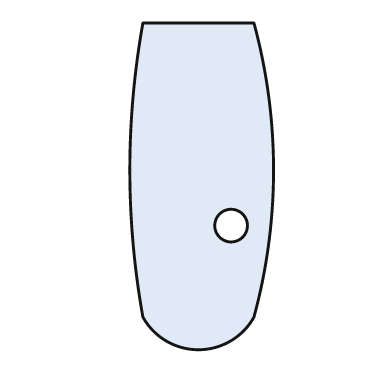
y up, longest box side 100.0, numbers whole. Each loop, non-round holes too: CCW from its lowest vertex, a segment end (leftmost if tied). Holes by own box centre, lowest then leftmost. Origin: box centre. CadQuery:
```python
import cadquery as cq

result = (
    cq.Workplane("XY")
    .moveTo(-18.0, -40.0)
    .threePointArc((-1.0, -50.0), (16.0, -40.0))
    .threePointArc((22.0, 5.0), (16.0, 50.0))
    .lineTo(-18.0, 50.0)
    .threePointArc((-22.0, 5.0), (-18.0, -40.0))
    .close()
    .moveTo(9.0, -12.0)
    .circle(5.0)
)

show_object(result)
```